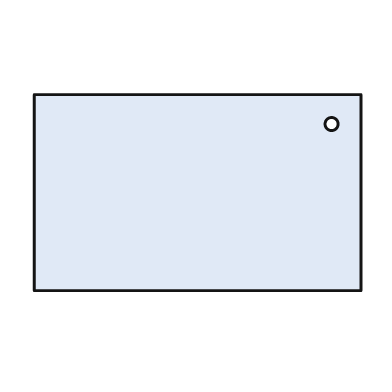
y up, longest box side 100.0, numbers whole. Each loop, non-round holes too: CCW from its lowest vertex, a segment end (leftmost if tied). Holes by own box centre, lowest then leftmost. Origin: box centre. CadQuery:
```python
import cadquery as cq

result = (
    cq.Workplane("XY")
    .moveTo(-50.0, -30.0)
    .lineTo(50.0, -30.0)
    .lineTo(50.0, 30.0)
    .lineTo(-50.0, 30.0)
    .close()
    .moveTo(41.0, 21.0)
    .circle(2.0)
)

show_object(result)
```